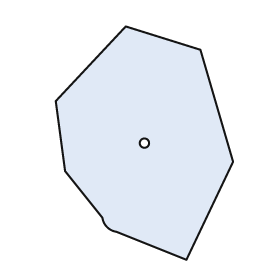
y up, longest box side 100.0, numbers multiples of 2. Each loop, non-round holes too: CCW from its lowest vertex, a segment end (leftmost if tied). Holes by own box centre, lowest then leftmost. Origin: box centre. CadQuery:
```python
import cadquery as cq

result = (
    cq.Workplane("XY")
    .moveTo(18.0, -50.0)
    .lineTo(38.0, -8.0)
    .lineTo(24.0, 40.0)
    .lineTo(-8.0, 50.0)
    .lineTo(-38.0, 18.0)
    .lineTo(-34.0, -12.0)
    .lineTo(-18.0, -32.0)
    .threePointArc((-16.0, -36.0), (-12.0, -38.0))
    .close()
    .moveTo(0.0, 0.0)
    .circle(2.0)
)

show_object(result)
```